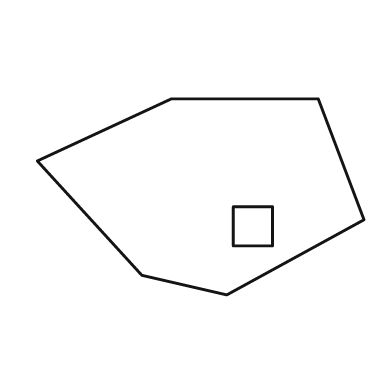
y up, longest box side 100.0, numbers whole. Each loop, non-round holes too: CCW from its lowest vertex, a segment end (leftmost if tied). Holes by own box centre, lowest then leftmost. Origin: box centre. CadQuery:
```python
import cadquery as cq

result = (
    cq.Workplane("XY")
    .moveTo(8.0, -30.0)
    .lineTo(50.0, -7.0)
    .lineTo(36.0, 30.0)
    .lineTo(-9.0, 30.0)
    .lineTo(-50.0, 11.0)
    .lineTo(-18.0, -24.0)
    .close()
    .moveTo(10.0, -15.0)
    .lineTo(22.0, -15.0)
    .lineTo(22.0, -3.0)
    .lineTo(10.0, -3.0)
    .close()
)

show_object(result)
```